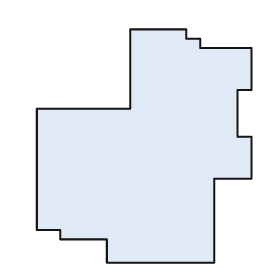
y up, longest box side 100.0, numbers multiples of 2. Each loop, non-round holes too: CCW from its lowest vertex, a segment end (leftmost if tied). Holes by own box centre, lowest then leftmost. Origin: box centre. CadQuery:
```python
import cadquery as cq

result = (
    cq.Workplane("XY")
    .moveTo(-16.0, -50.0)
    .lineTo(30.0, -50.0)
    .lineTo(30.0, -14.0)
    .lineTo(46.0, -14.0)
    .lineTo(46.0, 4.0)
    .lineTo(40.0, 4.0)
    .lineTo(40.0, 24.0)
    .lineTo(46.0, 24.0)
    .lineTo(46.0, 42.0)
    .lineTo(24.0, 42.0)
    .lineTo(24.0, 46.0)
    .lineTo(18.0, 46.0)
    .lineTo(18.0, 50.0)
    .lineTo(-6.0, 50.0)
    .lineTo(-6.0, 16.0)
    .lineTo(-46.0, 16.0)
    .lineTo(-46.0, -36.0)
    .lineTo(-36.0, -36.0)
    .lineTo(-36.0, -40.0)
    .lineTo(-16.0, -40.0)
    .close()
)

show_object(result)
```